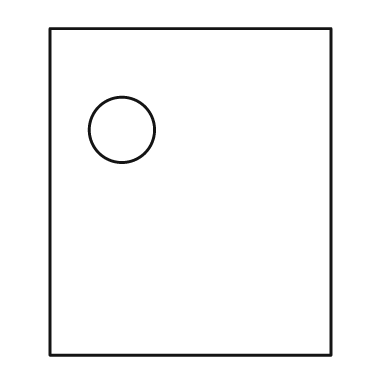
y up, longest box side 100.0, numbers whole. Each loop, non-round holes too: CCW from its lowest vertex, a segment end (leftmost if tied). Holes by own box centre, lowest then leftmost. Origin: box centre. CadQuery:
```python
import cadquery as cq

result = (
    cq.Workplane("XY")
    .moveTo(-43.0, -50.0)
    .lineTo(43.0, -50.0)
    .lineTo(43.0, 50.0)
    .lineTo(-43.0, 50.0)
    .close()
    .moveTo(-21.0, 19.0)
    .circle(10.0)
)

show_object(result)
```